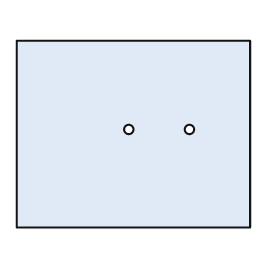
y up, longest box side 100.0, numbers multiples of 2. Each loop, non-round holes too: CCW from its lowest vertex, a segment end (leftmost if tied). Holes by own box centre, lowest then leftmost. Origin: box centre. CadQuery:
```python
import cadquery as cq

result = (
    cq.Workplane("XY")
    .moveTo(-50.0, -40.0)
    .lineTo(50.0, -40.0)
    .lineTo(50.0, 40.0)
    .lineTo(-50.0, 40.0)
    .close()
    .moveTo(-2.0, 2.0)
    .circle(2.0)
    .moveTo(24.0, 2.0)
    .circle(2.0)
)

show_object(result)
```